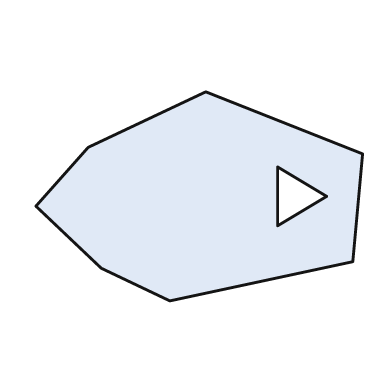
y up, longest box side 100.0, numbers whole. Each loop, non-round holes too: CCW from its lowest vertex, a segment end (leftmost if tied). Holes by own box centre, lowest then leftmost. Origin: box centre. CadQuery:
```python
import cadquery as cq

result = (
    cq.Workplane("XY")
    .moveTo(-9.0, -32.0)
    .lineTo(47.0, -20.0)
    .lineTo(50.0, 13.0)
    .lineTo(2.0, 32.0)
    .lineTo(-34.0, 15.0)
    .lineTo(-50.0, -3.0)
    .lineTo(-30.0, -22.0)
    .close()
    .moveTo(24.0, -9.0)
    .lineTo(39.0, 0.0)
    .lineTo(24.0, 9.0)
    .close()
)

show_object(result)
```